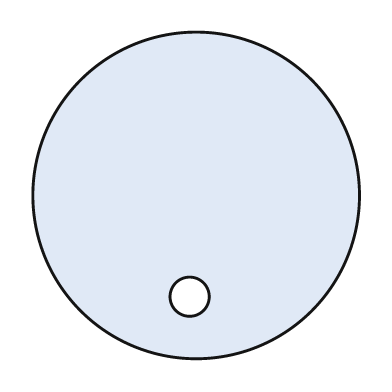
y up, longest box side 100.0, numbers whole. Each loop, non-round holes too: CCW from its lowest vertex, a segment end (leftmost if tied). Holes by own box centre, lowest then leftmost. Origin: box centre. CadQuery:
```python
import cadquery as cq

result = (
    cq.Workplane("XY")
    .moveTo(0.0, 0.0)
    .circle(50.0)
    .moveTo(-2.0, -31.0)
    .circle(6.0)
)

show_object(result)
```